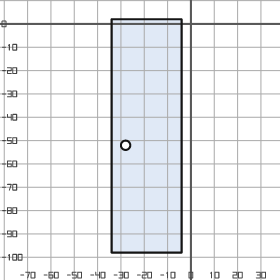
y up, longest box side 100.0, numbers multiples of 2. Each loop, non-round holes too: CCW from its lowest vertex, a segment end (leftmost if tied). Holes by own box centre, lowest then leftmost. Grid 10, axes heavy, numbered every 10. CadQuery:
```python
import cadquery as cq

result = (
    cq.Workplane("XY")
    .moveTo(-34.0, -98.0)
    .lineTo(-4.0, -98.0)
    .lineTo(-4.0, 2.0)
    .lineTo(-34.0, 2.0)
    .close()
    .moveTo(-28.0, -52.0)
    .circle(2.0)
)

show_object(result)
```